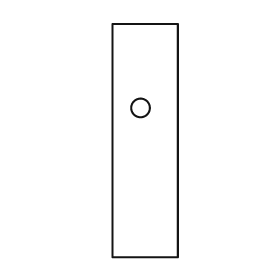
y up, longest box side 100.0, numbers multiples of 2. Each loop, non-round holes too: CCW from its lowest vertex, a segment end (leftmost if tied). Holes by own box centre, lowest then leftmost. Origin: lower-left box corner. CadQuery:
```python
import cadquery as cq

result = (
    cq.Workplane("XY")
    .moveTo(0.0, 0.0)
    .lineTo(28.0, 0.0)
    .lineTo(28.0, 100.0)
    .lineTo(0.0, 100.0)
    .close()
    .moveTo(12.0, 64.0)
    .circle(4.0)
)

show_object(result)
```